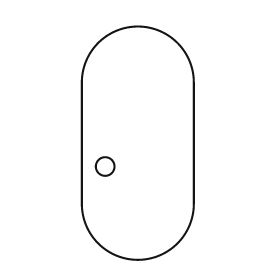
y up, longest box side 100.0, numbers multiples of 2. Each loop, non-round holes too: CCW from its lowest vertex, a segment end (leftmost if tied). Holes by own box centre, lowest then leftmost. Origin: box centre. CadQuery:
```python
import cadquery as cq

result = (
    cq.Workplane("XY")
    .moveTo(-24.0, -26.0)
    .threePointArc((0.0, -50.0), (24.0, -26.0))
    .lineTo(24.0, 26.0)
    .threePointArc((0.0, 50.0), (-24.0, 26.0))
    .close()
    .moveTo(-14.0, -10.0)
    .circle(4.0)
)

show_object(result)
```